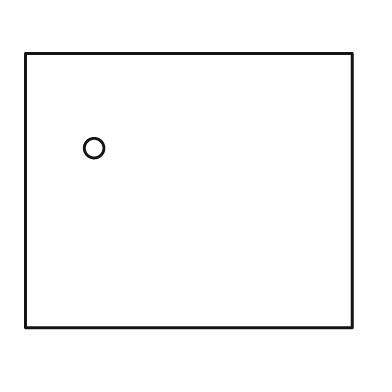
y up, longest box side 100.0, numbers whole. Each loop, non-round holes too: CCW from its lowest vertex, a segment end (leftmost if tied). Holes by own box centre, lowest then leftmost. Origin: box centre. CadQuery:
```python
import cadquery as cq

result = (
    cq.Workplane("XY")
    .moveTo(-50.0, -42.0)
    .lineTo(50.0, -42.0)
    .lineTo(50.0, 42.0)
    .lineTo(-50.0, 42.0)
    .close()
    .moveTo(-29.0, 13.0)
    .circle(3.0)
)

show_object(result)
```